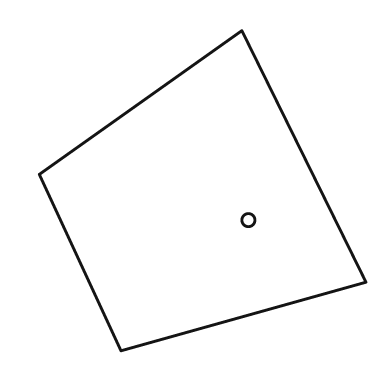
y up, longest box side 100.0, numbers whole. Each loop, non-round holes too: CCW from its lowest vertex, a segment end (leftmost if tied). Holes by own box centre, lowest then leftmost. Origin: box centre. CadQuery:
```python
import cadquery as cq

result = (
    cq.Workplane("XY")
    .moveTo(-25.0, -49.0)
    .lineTo(50.0, -28.0)
    .lineTo(12.0, 49.0)
    .lineTo(-50.0, 5.0)
    .close()
    .moveTo(14.0, -9.0)
    .circle(2.0)
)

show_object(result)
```